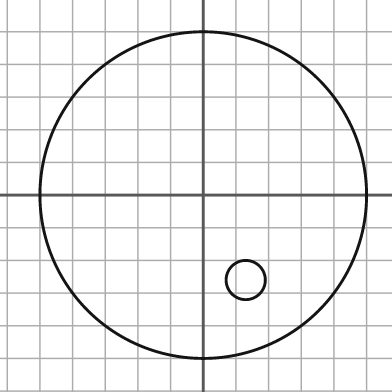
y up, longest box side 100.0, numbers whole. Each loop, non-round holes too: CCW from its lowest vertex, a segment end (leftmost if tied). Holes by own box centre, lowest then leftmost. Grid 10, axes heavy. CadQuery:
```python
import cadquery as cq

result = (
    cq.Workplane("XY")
    .moveTo(0.0, 0.0)
    .circle(50.0)
    .moveTo(13.0, -26.0)
    .circle(6.0)
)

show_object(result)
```